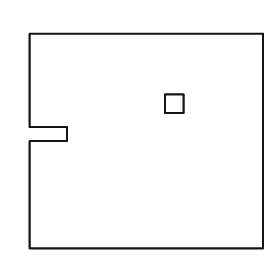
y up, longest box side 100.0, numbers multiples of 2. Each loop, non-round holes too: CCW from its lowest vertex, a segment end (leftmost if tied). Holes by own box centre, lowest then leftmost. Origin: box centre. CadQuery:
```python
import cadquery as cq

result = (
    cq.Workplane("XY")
    .moveTo(-50.0, -46.0)
    .lineTo(50.0, -46.0)
    .lineTo(50.0, 46.0)
    .lineTo(-50.0, 46.0)
    .lineTo(-50.0, 6.0)
    .lineTo(-34.0, 6.0)
    .lineTo(-34.0, 0.0)
    .lineTo(-50.0, 0.0)
    .close()
    .moveTo(8.0, 12.0)
    .lineTo(16.0, 12.0)
    .lineTo(16.0, 20.0)
    .lineTo(8.0, 20.0)
    .close()
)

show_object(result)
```